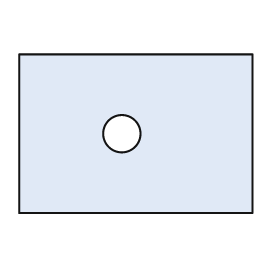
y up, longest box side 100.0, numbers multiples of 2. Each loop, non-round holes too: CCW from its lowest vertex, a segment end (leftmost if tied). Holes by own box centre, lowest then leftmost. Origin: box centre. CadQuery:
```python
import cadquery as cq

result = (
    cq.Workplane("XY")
    .moveTo(-50.0, -34.0)
    .lineTo(50.0, -34.0)
    .lineTo(50.0, 34.0)
    .lineTo(-50.0, 34.0)
    .close()
    .moveTo(-6.0, 0.0)
    .circle(8.0)
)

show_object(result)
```